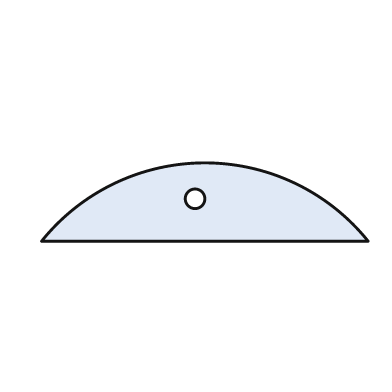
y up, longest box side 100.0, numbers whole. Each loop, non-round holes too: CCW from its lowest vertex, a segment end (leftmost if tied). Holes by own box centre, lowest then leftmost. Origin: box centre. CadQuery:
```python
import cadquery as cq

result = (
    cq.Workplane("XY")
    .moveTo(-50.0, -12.0)
    .lineTo(50.0, -12.0)
    .threePointArc((0.0, 12.0), (-50.0, -12.0))
    .close()
    .moveTo(-3.0, 1.0)
    .circle(3.0)
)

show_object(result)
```